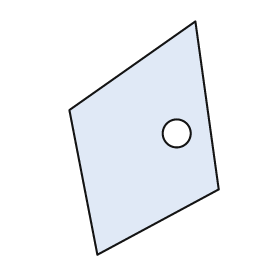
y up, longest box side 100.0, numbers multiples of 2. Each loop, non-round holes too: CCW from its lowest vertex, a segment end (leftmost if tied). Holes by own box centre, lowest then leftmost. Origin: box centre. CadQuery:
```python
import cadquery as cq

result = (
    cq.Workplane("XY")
    .moveTo(-20.0, -50.0)
    .lineTo(32.0, -22.0)
    .lineTo(22.0, 50.0)
    .lineTo(-32.0, 12.0)
    .close()
    .moveTo(14.0, 2.0)
    .circle(6.0)
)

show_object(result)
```